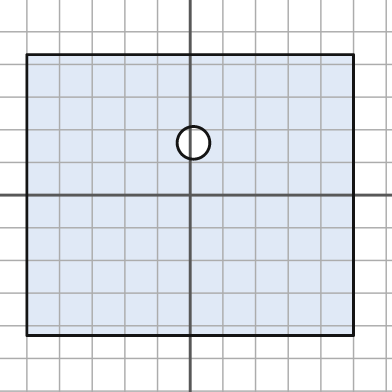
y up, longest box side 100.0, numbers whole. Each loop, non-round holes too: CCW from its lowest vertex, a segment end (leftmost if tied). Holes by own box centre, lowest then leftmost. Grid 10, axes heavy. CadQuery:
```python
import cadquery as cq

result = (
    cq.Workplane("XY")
    .moveTo(-50.0, -43.0)
    .lineTo(50.0, -43.0)
    .lineTo(50.0, 43.0)
    .lineTo(-50.0, 43.0)
    .close()
    .moveTo(1.0, 16.0)
    .circle(5.0)
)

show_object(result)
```